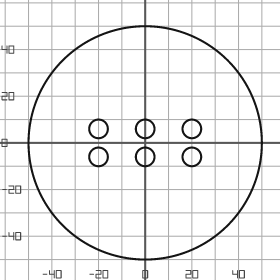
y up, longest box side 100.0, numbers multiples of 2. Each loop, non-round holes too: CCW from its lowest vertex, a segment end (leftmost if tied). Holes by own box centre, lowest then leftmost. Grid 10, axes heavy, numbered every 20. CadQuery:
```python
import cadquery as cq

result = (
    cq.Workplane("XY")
    .moveTo(0.0, 0.0)
    .circle(50.0)
    .moveTo(-20.0, -6.0)
    .circle(4.0)
    .moveTo(0.0, -6.0)
    .circle(4.0)
    .moveTo(20.0, -6.0)
    .circle(4.0)
    .moveTo(-20.0, 6.0)
    .circle(4.0)
    .moveTo(0.0, 6.0)
    .circle(4.0)
    .moveTo(20.0, 6.0)
    .circle(4.0)
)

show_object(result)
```